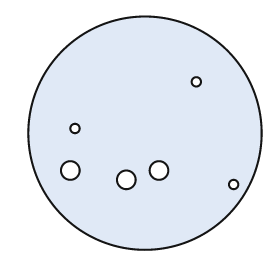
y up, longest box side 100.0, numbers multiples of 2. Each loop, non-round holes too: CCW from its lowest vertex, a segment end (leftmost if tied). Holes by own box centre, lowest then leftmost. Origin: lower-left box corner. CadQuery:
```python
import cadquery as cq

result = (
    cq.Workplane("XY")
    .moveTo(50.0, 50.0)
    .circle(50.0)
    .moveTo(88.0, 28.0)
    .circle(2.0)
    .moveTo(42.0, 30.0)
    .circle(4.0)
    .moveTo(18.0, 34.0)
    .circle(4.0)
    .moveTo(56.0, 34.0)
    .circle(4.0)
    .moveTo(20.0, 52.0)
    .circle(2.0)
    .moveTo(72.0, 72.0)
    .circle(2.0)
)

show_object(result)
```